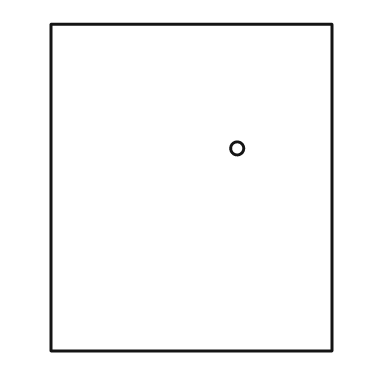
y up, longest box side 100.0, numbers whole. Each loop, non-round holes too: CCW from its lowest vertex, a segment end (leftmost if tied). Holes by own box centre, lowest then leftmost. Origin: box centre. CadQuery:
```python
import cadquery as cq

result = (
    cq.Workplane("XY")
    .moveTo(-43.0, -50.0)
    .lineTo(43.0, -50.0)
    .lineTo(43.0, 50.0)
    .lineTo(-43.0, 50.0)
    .close()
    .moveTo(14.0, 12.0)
    .circle(2.0)
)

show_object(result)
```